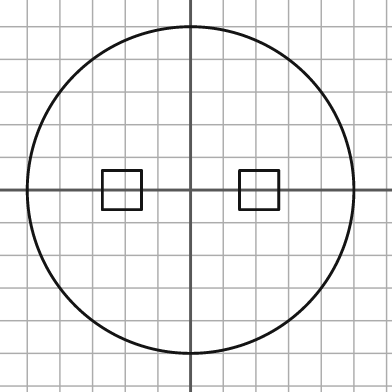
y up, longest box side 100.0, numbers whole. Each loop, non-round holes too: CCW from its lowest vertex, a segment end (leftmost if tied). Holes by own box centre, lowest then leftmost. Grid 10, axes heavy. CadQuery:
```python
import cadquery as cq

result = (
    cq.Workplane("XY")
    .moveTo(0.0, 0.0)
    .circle(50.0)
    .moveTo(-27.0, -6.0)
    .lineTo(-15.0, -6.0)
    .lineTo(-15.0, 6.0)
    .lineTo(-27.0, 6.0)
    .close()
    .moveTo(15.0, -6.0)
    .lineTo(27.0, -6.0)
    .lineTo(27.0, 6.0)
    .lineTo(15.0, 6.0)
    .close()
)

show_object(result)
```